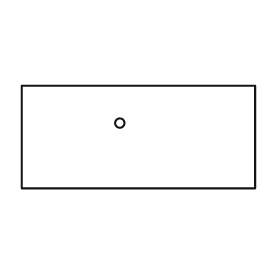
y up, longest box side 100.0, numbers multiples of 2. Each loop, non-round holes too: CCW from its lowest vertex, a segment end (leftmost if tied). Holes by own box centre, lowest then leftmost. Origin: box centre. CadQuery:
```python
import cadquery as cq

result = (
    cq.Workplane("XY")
    .moveTo(-50.0, -22.0)
    .lineTo(50.0, -22.0)
    .lineTo(50.0, 22.0)
    .lineTo(-50.0, 22.0)
    .close()
    .moveTo(-8.0, 6.0)
    .circle(2.0)
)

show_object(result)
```